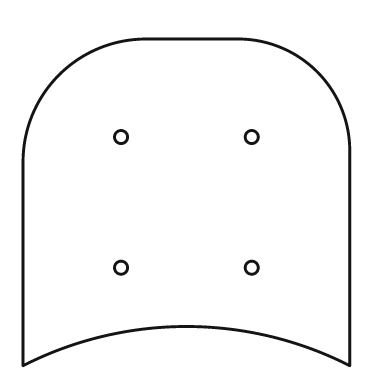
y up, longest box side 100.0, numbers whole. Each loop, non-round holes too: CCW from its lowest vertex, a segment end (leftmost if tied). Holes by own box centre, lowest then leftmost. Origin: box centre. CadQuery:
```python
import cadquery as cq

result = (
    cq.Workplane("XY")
    .moveTo(-50.0, -50.0)
    .threePointArc((0.0, -38.0), (50.0, -50.0))
    .lineTo(50.0, 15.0)
    .threePointArc((40.0, 40.0), (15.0, 50.0))
    .lineTo(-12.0, 50.0)
    .threePointArc((-39.0, 39.0), (-50.0, 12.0))
    .close()
    .moveTo(-20.0, -20.0)
    .circle(2.0)
    .moveTo(20.0, -20.0)
    .circle(2.0)
    .moveTo(-20.0, 20.0)
    .circle(2.0)
    .moveTo(20.0, 20.0)
    .circle(2.0)
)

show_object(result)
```